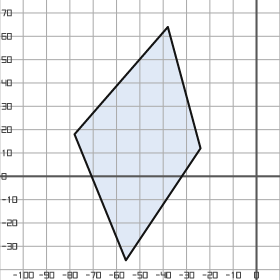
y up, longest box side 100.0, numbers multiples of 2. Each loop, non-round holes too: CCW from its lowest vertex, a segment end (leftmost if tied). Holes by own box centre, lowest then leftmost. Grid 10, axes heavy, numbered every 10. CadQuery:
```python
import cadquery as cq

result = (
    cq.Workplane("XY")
    .moveTo(-56.0, -36.0)
    .lineTo(-24.0, 12.0)
    .lineTo(-38.0, 64.0)
    .lineTo(-78.0, 18.0)
    .close()
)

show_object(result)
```